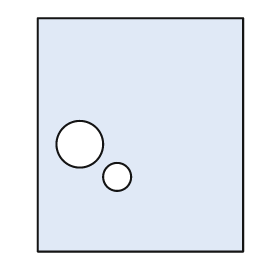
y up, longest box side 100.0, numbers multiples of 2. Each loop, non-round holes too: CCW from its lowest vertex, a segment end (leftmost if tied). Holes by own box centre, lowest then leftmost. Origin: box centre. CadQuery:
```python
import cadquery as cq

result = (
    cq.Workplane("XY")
    .moveTo(-44.0, -50.0)
    .lineTo(44.0, -50.0)
    .lineTo(44.0, 50.0)
    .lineTo(-44.0, 50.0)
    .close()
    .moveTo(-10.0, -18.0)
    .circle(6.0)
    .moveTo(-26.0, -4.0)
    .circle(10.0)
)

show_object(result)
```